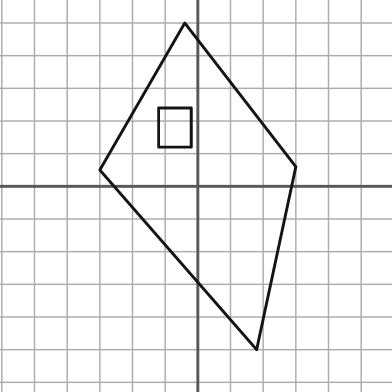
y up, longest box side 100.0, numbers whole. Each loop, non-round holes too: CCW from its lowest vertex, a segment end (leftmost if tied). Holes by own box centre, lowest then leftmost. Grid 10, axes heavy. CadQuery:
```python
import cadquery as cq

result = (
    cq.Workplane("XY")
    .moveTo(18.0, -50.0)
    .lineTo(30.0, 6.0)
    .lineTo(-4.0, 50.0)
    .lineTo(-30.0, 5.0)
    .close()
    .moveTo(-12.0, 12.0)
    .lineTo(-2.0, 12.0)
    .lineTo(-2.0, 24.0)
    .lineTo(-12.0, 24.0)
    .close()
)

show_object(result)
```